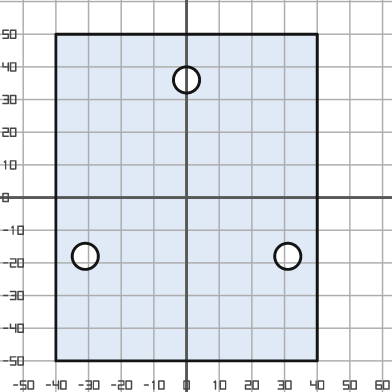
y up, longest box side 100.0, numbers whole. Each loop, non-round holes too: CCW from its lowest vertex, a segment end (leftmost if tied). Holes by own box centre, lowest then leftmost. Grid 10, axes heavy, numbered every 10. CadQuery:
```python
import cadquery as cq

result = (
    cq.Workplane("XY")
    .moveTo(-40.0, -50.0)
    .lineTo(40.0, -50.0)
    .lineTo(40.0, 50.0)
    .lineTo(-40.0, 50.0)
    .close()
    .moveTo(-31.0, -18.0)
    .circle(4.0)
    .moveTo(31.0, -18.0)
    .circle(4.0)
    .moveTo(0.0, 36.0)
    .circle(4.0)
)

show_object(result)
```